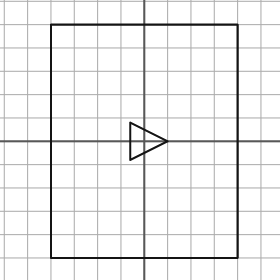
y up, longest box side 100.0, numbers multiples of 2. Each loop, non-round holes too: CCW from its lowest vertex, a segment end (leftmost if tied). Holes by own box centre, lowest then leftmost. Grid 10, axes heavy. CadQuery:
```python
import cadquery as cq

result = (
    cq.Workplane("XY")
    .moveTo(-40.0, -50.0)
    .lineTo(40.0, -50.0)
    .lineTo(40.0, 50.0)
    .lineTo(-40.0, 50.0)
    .close()
    .moveTo(-6.0, -8.0)
    .lineTo(10.0, 0.0)
    .lineTo(-6.0, 8.0)
    .close()
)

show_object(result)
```